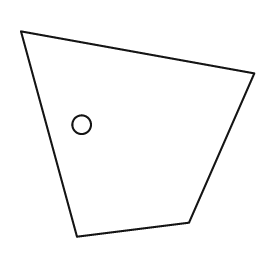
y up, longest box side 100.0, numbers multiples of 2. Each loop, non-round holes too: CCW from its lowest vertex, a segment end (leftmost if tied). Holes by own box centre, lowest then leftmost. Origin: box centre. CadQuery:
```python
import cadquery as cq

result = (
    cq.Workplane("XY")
    .moveTo(-26.0, -44.0)
    .lineTo(22.0, -38.0)
    .lineTo(50.0, 26.0)
    .lineTo(-50.0, 44.0)
    .close()
    .moveTo(-24.0, 4.0)
    .circle(4.0)
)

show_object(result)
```